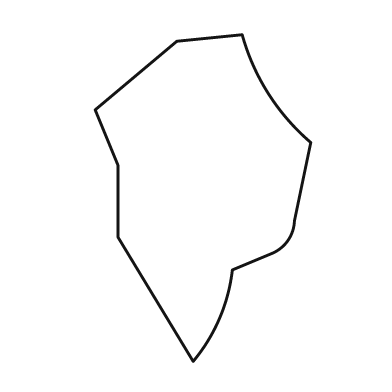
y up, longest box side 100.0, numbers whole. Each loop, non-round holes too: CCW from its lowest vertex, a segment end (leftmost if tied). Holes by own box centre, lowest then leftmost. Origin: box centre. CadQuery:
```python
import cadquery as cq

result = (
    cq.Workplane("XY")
    .moveTo(-3.0, -50.0)
    .threePointArc((5.0, -37.0), (9.0, -22.0))
    .lineTo(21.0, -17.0)
    .threePointArc((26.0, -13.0), (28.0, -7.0))
    .lineTo(33.0, 17.0)
    .threePointArc((20.0, 32.0), (12.0, 50.0))
    .lineTo(-8.0, 48.0)
    .lineTo(-33.0, 27.0)
    .lineTo(-26.0, 10.0)
    .lineTo(-26.0, -12.0)
    .close()
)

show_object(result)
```